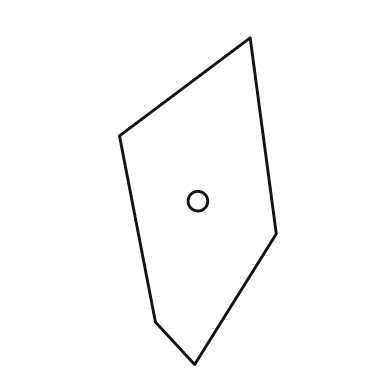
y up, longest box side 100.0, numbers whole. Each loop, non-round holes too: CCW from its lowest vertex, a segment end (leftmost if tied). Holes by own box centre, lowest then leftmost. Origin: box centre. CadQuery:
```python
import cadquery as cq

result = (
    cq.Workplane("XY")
    .moveTo(-1.0, -50.0)
    .lineTo(24.0, -10.0)
    .lineTo(16.0, 50.0)
    .lineTo(-24.0, 20.0)
    .lineTo(-13.0, -37.0)
    .close()
    .moveTo(0.0, 0.0)
    .circle(3.0)
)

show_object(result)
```